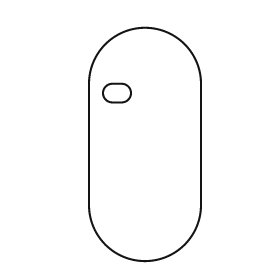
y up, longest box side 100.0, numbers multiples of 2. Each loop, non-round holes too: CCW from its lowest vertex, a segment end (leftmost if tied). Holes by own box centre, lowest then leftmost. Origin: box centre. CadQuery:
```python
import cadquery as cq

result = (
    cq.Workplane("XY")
    .moveTo(-24.0, -26.0)
    .threePointArc((0.0, -50.0), (24.0, -26.0))
    .lineTo(24.0, 26.0)
    .threePointArc((0.0, 50.0), (-24.0, 26.0))
    .close()
    .moveTo(-14.0, 18.0)
    .lineTo(-10.0, 18.0)
    .threePointArc((-6.0, 22.0), (-10.0, 26.0))
    .lineTo(-14.0, 26.0)
    .threePointArc((-18.0, 22.0), (-14.0, 18.0))
    .close()
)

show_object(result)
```